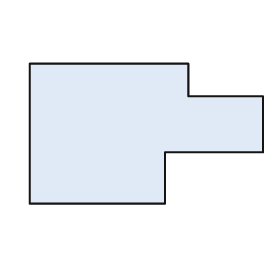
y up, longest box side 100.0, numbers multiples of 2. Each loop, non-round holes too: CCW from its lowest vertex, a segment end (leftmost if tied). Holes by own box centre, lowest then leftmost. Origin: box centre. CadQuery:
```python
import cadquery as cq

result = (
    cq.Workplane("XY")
    .moveTo(-50.0, -30.0)
    .lineTo(8.0, -30.0)
    .lineTo(8.0, -8.0)
    .lineTo(50.0, -8.0)
    .lineTo(50.0, 16.0)
    .lineTo(18.0, 16.0)
    .lineTo(18.0, 30.0)
    .lineTo(-50.0, 30.0)
    .close()
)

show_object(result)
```